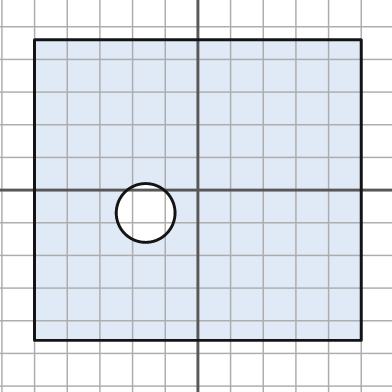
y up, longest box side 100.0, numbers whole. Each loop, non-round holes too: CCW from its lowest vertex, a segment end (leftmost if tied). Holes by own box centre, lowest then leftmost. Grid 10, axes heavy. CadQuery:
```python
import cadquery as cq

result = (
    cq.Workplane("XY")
    .moveTo(-50.0, -46.0)
    .lineTo(50.0, -46.0)
    .lineTo(50.0, 46.0)
    .lineTo(-50.0, 46.0)
    .close()
    .moveTo(-16.0, -7.0)
    .circle(9.0)
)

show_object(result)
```